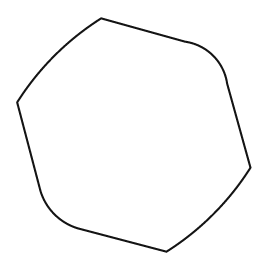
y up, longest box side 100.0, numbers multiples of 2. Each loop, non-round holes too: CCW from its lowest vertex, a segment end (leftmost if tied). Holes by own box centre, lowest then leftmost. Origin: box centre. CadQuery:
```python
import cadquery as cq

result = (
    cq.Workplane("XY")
    .moveTo(14.0, -50.0)
    .threePointArc((34.0, -34.0), (50.0, -14.0))
    .lineTo(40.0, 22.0)
    .threePointArc((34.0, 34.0), (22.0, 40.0))
    .lineTo(-14.0, 50.0)
    .threePointArc((-34.0, 34.0), (-50.0, 14.0))
    .lineTo(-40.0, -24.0)
    .threePointArc((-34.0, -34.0), (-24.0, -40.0))
    .close()
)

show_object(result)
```